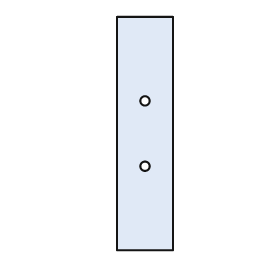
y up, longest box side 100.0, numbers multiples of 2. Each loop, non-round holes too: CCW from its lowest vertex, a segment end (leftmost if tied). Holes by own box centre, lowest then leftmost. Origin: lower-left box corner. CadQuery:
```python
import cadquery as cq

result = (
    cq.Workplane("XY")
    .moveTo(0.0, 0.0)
    .lineTo(24.0, 0.0)
    .lineTo(24.0, 100.0)
    .lineTo(0.0, 100.0)
    .close()
    .moveTo(12.0, 36.0)
    .circle(2.0)
    .moveTo(12.0, 64.0)
    .circle(2.0)
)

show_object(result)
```